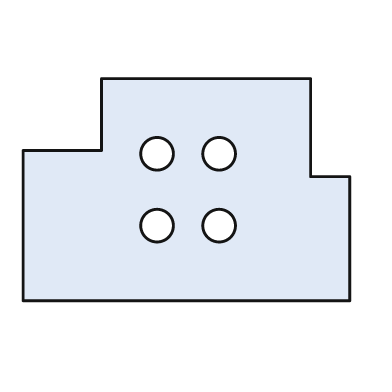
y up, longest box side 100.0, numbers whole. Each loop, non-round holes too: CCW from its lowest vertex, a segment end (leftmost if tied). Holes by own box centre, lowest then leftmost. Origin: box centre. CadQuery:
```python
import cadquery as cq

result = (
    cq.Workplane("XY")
    .moveTo(-50.0, -34.0)
    .lineTo(50.0, -34.0)
    .lineTo(50.0, 4.0)
    .lineTo(38.0, 4.0)
    .lineTo(38.0, 34.0)
    .lineTo(-26.0, 34.0)
    .lineTo(-26.0, 12.0)
    .lineTo(-50.0, 12.0)
    .close()
    .moveTo(-9.0, -11.0)
    .circle(5.0)
    .moveTo(10.0, -11.0)
    .circle(5.0)
    .moveTo(-9.0, 11.0)
    .circle(5.0)
    .moveTo(10.0, 11.0)
    .circle(5.0)
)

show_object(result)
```